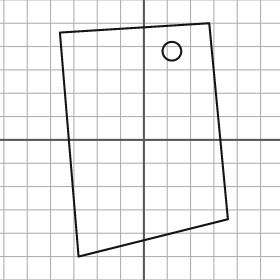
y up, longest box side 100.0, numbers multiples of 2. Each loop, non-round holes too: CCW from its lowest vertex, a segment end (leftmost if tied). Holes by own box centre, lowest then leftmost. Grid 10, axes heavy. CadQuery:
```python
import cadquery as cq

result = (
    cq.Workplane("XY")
    .moveTo(-28.0, -50.0)
    .lineTo(36.0, -34.0)
    .lineTo(28.0, 50.0)
    .lineTo(-36.0, 46.0)
    .close()
    .moveTo(12.0, 38.0)
    .circle(4.0)
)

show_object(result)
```